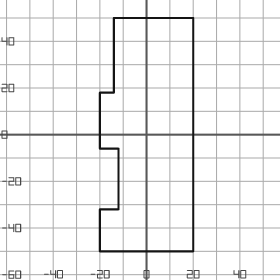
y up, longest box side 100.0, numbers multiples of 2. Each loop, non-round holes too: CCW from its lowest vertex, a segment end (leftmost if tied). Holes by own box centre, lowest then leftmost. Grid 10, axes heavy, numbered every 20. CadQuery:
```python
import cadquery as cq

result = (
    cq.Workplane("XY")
    .moveTo(-20.0, -50.0)
    .lineTo(20.0, -50.0)
    .lineTo(20.0, 50.0)
    .lineTo(-14.0, 50.0)
    .lineTo(-14.0, 18.0)
    .lineTo(-20.0, 18.0)
    .lineTo(-20.0, -6.0)
    .lineTo(-12.0, -6.0)
    .lineTo(-12.0, -32.0)
    .lineTo(-20.0, -32.0)
    .close()
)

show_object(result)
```